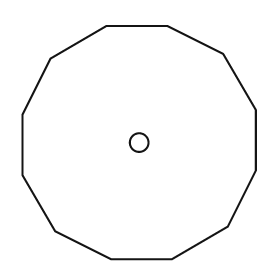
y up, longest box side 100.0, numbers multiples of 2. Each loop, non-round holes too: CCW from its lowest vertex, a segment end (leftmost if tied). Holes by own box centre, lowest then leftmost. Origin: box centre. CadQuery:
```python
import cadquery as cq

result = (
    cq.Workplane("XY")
    .moveTo(-12.0, -50.0)
    .lineTo(14.0, -50.0)
    .lineTo(38.0, -36.0)
    .lineTo(50.0, -12.0)
    .lineTo(50.0, 14.0)
    .lineTo(36.0, 38.0)
    .lineTo(12.0, 50.0)
    .lineTo(-14.0, 50.0)
    .lineTo(-38.0, 36.0)
    .lineTo(-50.0, 12.0)
    .lineTo(-50.0, -14.0)
    .lineTo(-36.0, -38.0)
    .close()
    .moveTo(0.0, 0.0)
    .circle(4.0)
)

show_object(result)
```